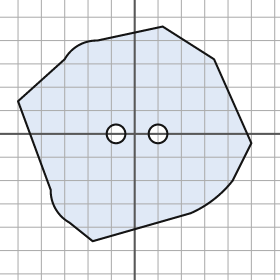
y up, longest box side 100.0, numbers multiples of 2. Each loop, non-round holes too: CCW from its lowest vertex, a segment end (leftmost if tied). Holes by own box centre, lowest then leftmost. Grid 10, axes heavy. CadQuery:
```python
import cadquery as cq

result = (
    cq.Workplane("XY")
    .moveTo(-18.0, -46.0)
    .lineTo(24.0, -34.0)
    .threePointArc((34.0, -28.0), (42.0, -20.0))
    .lineTo(50.0, -4.0)
    .lineTo(34.0, 32.0)
    .lineTo(12.0, 46.0)
    .lineTo(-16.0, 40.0)
    .threePointArc((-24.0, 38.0), (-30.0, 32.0))
    .lineTo(-50.0, 14.0)
    .lineTo(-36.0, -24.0)
    .threePointArc((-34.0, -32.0), (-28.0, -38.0))
    .close()
    .moveTo(-8.0, 0.0)
    .circle(4.0)
    .moveTo(10.0, 0.0)
    .circle(4.0)
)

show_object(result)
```